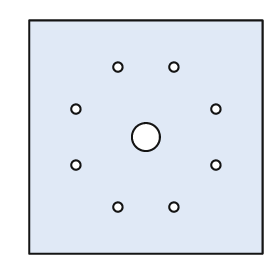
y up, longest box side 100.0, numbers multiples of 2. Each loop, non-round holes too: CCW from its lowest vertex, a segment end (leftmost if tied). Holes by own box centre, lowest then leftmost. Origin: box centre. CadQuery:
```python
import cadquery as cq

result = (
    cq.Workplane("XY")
    .moveTo(-50.0, -50.0)
    .lineTo(50.0, -50.0)
    .lineTo(50.0, 50.0)
    .lineTo(-50.0, 50.0)
    .close()
    .moveTo(-12.0, -30.0)
    .circle(2.0)
    .moveTo(12.0, -30.0)
    .circle(2.0)
    .moveTo(-30.0, -12.0)
    .circle(2.0)
    .moveTo(30.0, -12.0)
    .circle(2.0)
    .moveTo(0.0, 0.0)
    .circle(6.0)
    .moveTo(-30.0, 12.0)
    .circle(2.0)
    .moveTo(30.0, 12.0)
    .circle(2.0)
    .moveTo(-12.0, 30.0)
    .circle(2.0)
    .moveTo(12.0, 30.0)
    .circle(2.0)
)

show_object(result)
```